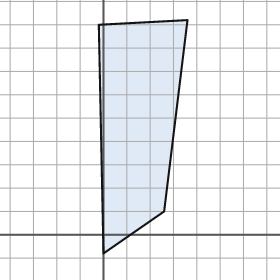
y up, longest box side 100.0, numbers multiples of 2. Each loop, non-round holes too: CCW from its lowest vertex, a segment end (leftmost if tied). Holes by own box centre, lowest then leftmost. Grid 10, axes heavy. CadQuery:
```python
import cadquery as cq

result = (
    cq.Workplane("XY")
    .moveTo(0.0, -8.0)
    .lineTo(26.0, 10.0)
    .lineTo(36.0, 92.0)
    .lineTo(-2.0, 90.0)
    .close()
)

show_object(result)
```